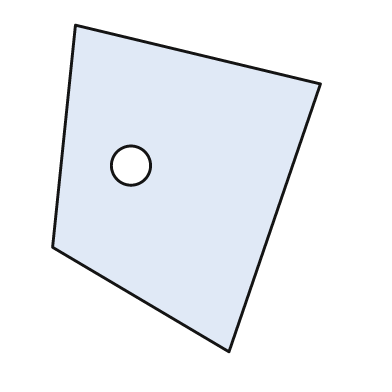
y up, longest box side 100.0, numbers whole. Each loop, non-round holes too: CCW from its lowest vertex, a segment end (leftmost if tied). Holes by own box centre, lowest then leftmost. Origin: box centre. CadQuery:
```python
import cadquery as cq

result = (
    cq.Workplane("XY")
    .moveTo(13.0, -50.0)
    .lineTo(41.0, 32.0)
    .lineTo(-34.0, 50.0)
    .lineTo(-41.0, -18.0)
    .close()
    .moveTo(-17.0, 7.0)
    .circle(6.0)
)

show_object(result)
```